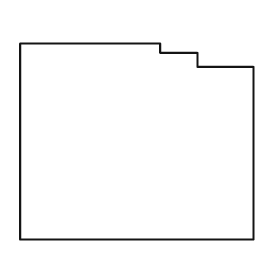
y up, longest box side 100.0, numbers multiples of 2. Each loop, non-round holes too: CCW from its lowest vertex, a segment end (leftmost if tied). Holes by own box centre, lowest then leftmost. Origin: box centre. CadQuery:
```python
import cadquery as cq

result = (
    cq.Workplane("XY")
    .moveTo(-50.0, -42.0)
    .lineTo(50.0, -42.0)
    .lineTo(50.0, 32.0)
    .lineTo(26.0, 32.0)
    .lineTo(26.0, 38.0)
    .lineTo(10.0, 38.0)
    .lineTo(10.0, 42.0)
    .lineTo(-50.0, 42.0)
    .close()
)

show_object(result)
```